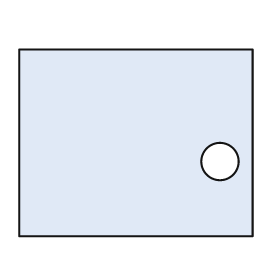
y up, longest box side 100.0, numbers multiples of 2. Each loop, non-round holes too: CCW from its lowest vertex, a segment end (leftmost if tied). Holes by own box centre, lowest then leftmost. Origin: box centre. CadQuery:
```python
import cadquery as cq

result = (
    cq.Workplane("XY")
    .moveTo(-50.0, -40.0)
    .lineTo(50.0, -40.0)
    .lineTo(50.0, 40.0)
    .lineTo(-50.0, 40.0)
    .close()
    .moveTo(36.0, -8.0)
    .circle(8.0)
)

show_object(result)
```